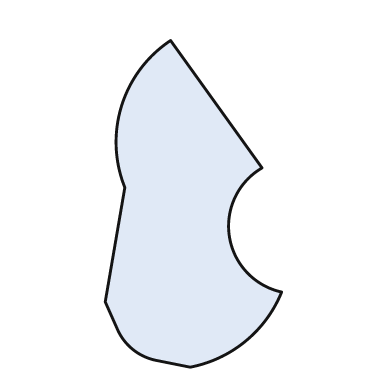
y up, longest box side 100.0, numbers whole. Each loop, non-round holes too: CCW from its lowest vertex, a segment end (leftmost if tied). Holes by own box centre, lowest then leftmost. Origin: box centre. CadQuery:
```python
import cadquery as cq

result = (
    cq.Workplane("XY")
    .moveTo(-1.0, -50.0)
    .threePointArc((16.0, -42.0), (27.0, -27.0))
    .threePointArc((11.0, -10.0), (21.0, 11.0))
    .lineTo(-7.0, 50.0)
    .threePointArc((-22.0, 30.0), (-21.0, 5.0))
    .lineTo(-27.0, -30.0)
    .lineTo(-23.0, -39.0)
    .threePointArc((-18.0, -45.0), (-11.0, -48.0))
    .close()
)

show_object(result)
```